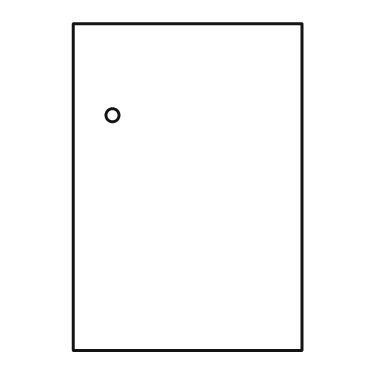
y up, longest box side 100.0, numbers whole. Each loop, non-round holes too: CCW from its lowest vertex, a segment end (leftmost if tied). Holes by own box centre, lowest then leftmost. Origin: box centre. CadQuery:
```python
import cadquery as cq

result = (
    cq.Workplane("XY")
    .moveTo(-35.0, -50.0)
    .lineTo(35.0, -50.0)
    .lineTo(35.0, 50.0)
    .lineTo(-35.0, 50.0)
    .close()
    .moveTo(-23.0, 22.0)
    .circle(2.0)
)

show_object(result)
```